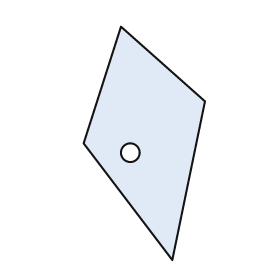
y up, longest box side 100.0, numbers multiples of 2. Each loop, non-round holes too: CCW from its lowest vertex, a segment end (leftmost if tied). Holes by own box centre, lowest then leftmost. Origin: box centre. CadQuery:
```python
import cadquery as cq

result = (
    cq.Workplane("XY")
    .moveTo(12.0, -50.0)
    .lineTo(26.0, 18.0)
    .lineTo(-10.0, 50.0)
    .lineTo(-26.0, 0.0)
    .close()
    .moveTo(-6.0, -4.0)
    .circle(4.0)
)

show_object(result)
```